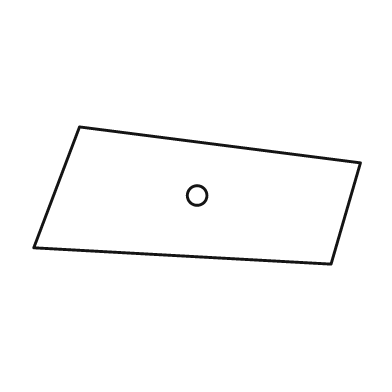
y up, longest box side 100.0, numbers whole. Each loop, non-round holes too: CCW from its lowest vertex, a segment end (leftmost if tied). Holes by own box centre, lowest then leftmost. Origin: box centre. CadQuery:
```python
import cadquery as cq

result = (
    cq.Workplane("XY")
    .moveTo(41.0, -21.0)
    .lineTo(50.0, 10.0)
    .lineTo(-36.0, 21.0)
    .lineTo(-50.0, -16.0)
    .close()
    .moveTo(0.0, 0.0)
    .circle(3.0)
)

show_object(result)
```